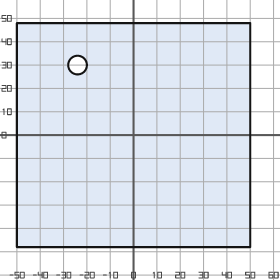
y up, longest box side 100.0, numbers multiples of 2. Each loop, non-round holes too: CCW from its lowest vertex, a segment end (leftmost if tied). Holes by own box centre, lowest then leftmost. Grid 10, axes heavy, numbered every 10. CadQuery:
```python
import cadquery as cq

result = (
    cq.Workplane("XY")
    .moveTo(-50.0, -48.0)
    .lineTo(50.0, -48.0)
    .lineTo(50.0, 48.0)
    .lineTo(-50.0, 48.0)
    .close()
    .moveTo(-24.0, 30.0)
    .circle(4.0)
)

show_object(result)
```